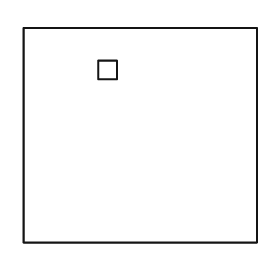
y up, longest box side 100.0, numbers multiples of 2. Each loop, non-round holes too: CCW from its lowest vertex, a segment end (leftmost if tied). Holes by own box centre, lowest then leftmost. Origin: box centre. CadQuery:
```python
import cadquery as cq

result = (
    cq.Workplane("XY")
    .moveTo(-50.0, -46.0)
    .lineTo(50.0, -46.0)
    .lineTo(50.0, 46.0)
    .lineTo(-50.0, 46.0)
    .close()
    .moveTo(-18.0, 24.0)
    .lineTo(-10.0, 24.0)
    .lineTo(-10.0, 32.0)
    .lineTo(-18.0, 32.0)
    .close()
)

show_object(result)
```